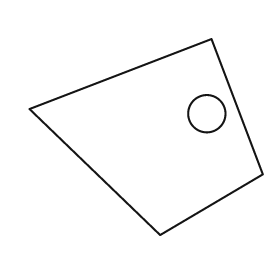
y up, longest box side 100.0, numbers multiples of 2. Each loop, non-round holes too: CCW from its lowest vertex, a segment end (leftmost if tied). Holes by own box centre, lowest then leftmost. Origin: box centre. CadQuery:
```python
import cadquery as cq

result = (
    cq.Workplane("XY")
    .moveTo(6.0, -42.0)
    .lineTo(50.0, -16.0)
    .lineTo(28.0, 42.0)
    .lineTo(-50.0, 12.0)
    .close()
    .moveTo(26.0, 10.0)
    .circle(8.0)
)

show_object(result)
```